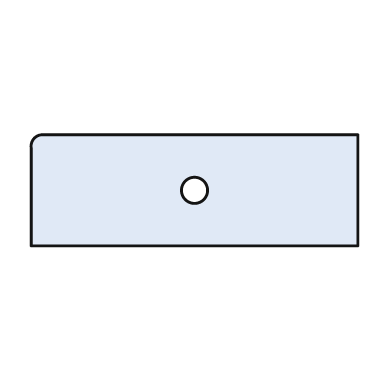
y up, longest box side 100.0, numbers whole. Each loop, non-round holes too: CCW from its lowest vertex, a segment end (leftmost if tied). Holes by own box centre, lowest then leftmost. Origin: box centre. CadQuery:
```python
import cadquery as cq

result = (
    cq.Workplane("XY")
    .moveTo(-50.0, -17.0)
    .lineTo(50.0, -17.0)
    .lineTo(50.0, 17.0)
    .lineTo(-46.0, 17.0)
    .threePointArc((-49.0, 16.0), (-50.0, 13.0))
    .close()
    .moveTo(0.0, 0.0)
    .circle(4.0)
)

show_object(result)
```